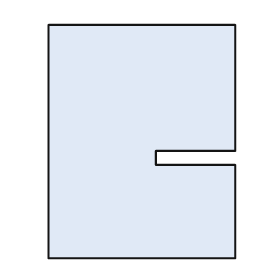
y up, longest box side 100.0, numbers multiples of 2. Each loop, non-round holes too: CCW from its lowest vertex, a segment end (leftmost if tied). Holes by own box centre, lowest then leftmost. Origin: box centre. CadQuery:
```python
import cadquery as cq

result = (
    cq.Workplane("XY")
    .moveTo(-40.0, -50.0)
    .lineTo(40.0, -50.0)
    .lineTo(40.0, -10.0)
    .lineTo(6.0, -10.0)
    .lineTo(6.0, -4.0)
    .lineTo(40.0, -4.0)
    .lineTo(40.0, 50.0)
    .lineTo(-40.0, 50.0)
    .close()
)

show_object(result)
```